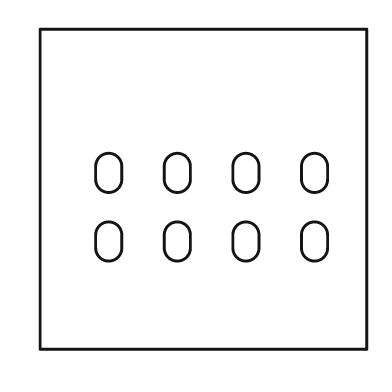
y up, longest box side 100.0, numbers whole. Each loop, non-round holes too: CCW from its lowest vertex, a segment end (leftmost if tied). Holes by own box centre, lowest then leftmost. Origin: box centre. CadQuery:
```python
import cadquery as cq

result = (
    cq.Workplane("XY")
    .moveTo(-50.0, -49.0)
    .lineTo(50.0, -49.0)
    .lineTo(50.0, 49.0)
    .lineTo(-50.0, 49.0)
    .close()
    .moveTo(-33.0, -18.0)
    .threePointArc((-29.0, -22.0), (-25.0, -18.0))
    .lineTo(-25.0, -14.0)
    .threePointArc((-29.0, -10.0), (-33.0, -14.0))
    .close()
    .moveTo(-12.0, -18.0)
    .threePointArc((-8.0, -22.0), (-4.0, -18.0))
    .lineTo(-4.0, -14.0)
    .threePointArc((-8.0, -10.0), (-12.0, -14.0))
    .close()
    .moveTo(9.0, -18.0)
    .threePointArc((13.0, -22.0), (17.0, -18.0))
    .lineTo(17.0, -14.0)
    .threePointArc((13.0, -10.0), (9.0, -14.0))
    .close()
    .moveTo(30.0, -18.0)
    .threePointArc((34.0, -22.0), (38.0, -18.0))
    .lineTo(38.0, -14.0)
    .threePointArc((34.0, -10.0), (30.0, -14.0))
    .close()
    .moveTo(-33.0, 3.0)
    .threePointArc((-29.0, -1.0), (-25.0, 3.0))
    .lineTo(-25.0, 7.0)
    .threePointArc((-29.0, 11.0), (-33.0, 7.0))
    .close()
    .moveTo(-12.0, 3.0)
    .threePointArc((-8.0, -1.0), (-4.0, 3.0))
    .lineTo(-4.0, 7.0)
    .threePointArc((-8.0, 11.0), (-12.0, 7.0))
    .close()
    .moveTo(9.0, 3.0)
    .threePointArc((13.0, -1.0), (17.0, 3.0))
    .lineTo(17.0, 7.0)
    .threePointArc((13.0, 11.0), (9.0, 7.0))
    .close()
    .moveTo(30.0, 3.0)
    .threePointArc((34.0, -1.0), (38.0, 3.0))
    .lineTo(38.0, 7.0)
    .threePointArc((34.0, 11.0), (30.0, 7.0))
    .close()
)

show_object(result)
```